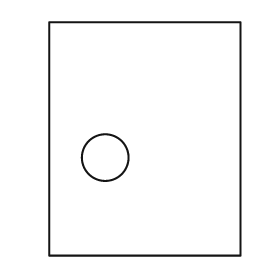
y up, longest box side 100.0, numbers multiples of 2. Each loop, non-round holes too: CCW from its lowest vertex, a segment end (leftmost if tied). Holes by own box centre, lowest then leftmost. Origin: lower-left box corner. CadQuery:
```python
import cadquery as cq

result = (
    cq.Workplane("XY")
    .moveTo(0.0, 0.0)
    .lineTo(82.0, 0.0)
    .lineTo(82.0, 100.0)
    .lineTo(0.0, 100.0)
    .close()
    .moveTo(24.0, 42.0)
    .circle(10.0)
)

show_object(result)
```